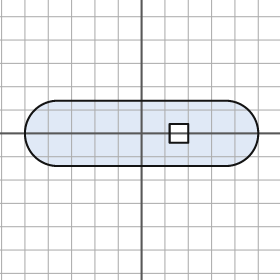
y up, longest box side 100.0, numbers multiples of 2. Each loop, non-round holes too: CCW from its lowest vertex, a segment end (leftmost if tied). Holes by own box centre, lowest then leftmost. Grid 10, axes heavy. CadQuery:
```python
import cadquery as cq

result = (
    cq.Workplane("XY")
    .moveTo(-36.0, -14.0)
    .lineTo(36.0, -14.0)
    .threePointArc((50.0, 0.0), (36.0, 14.0))
    .lineTo(-36.0, 14.0)
    .threePointArc((-50.0, 0.0), (-36.0, -14.0))
    .close()
    .moveTo(12.0, -4.0)
    .lineTo(20.0, -4.0)
    .lineTo(20.0, 4.0)
    .lineTo(12.0, 4.0)
    .close()
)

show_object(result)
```